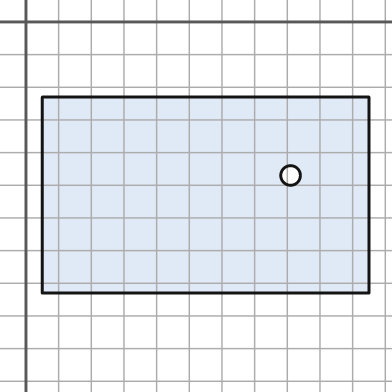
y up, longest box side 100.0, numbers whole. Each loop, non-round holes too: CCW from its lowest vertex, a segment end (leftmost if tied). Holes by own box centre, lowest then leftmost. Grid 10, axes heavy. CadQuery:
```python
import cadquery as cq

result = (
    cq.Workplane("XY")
    .moveTo(5.0, -83.0)
    .lineTo(105.0, -83.0)
    .lineTo(105.0, -23.0)
    .lineTo(5.0, -23.0)
    .close()
    .moveTo(81.0, -47.0)
    .circle(3.0)
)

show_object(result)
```